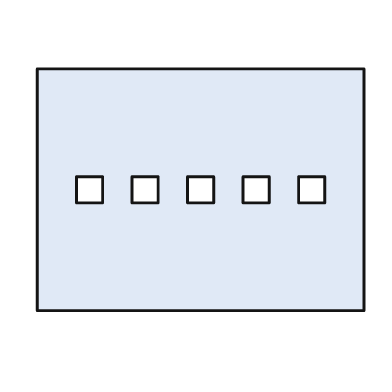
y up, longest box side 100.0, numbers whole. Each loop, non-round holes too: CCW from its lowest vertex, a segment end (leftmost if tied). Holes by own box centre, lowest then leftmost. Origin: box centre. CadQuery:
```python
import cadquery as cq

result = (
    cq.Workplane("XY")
    .moveTo(-50.0, -37.0)
    .lineTo(50.0, -37.0)
    .lineTo(50.0, 37.0)
    .lineTo(-50.0, 37.0)
    .close()
    .moveTo(-38.0, -4.0)
    .lineTo(-30.0, -4.0)
    .lineTo(-30.0, 4.0)
    .lineTo(-38.0, 4.0)
    .close()
    .moveTo(-21.0, -4.0)
    .lineTo(-13.0, -4.0)
    .lineTo(-13.0, 4.0)
    .lineTo(-21.0, 4.0)
    .close()
    .moveTo(-4.0, -4.0)
    .lineTo(4.0, -4.0)
    .lineTo(4.0, 4.0)
    .lineTo(-4.0, 4.0)
    .close()
    .moveTo(13.0, -4.0)
    .lineTo(21.0, -4.0)
    .lineTo(21.0, 4.0)
    .lineTo(13.0, 4.0)
    .close()
    .moveTo(30.0, -4.0)
    .lineTo(38.0, -4.0)
    .lineTo(38.0, 4.0)
    .lineTo(30.0, 4.0)
    .close()
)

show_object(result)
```